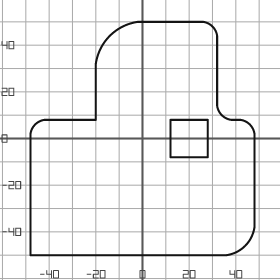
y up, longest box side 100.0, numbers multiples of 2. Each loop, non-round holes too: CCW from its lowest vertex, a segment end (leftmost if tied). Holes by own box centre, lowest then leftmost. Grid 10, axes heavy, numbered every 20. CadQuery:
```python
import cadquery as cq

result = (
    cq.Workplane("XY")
    .moveTo(-48.0, -50.0)
    .lineTo(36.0, -50.0)
    .threePointArc((44.0, -46.0), (48.0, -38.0))
    .lineTo(48.0, 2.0)
    .threePointArc((46.0, 6.0), (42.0, 8.0))
    .lineTo(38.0, 8.0)
    .threePointArc((34.0, 10.0), (32.0, 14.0))
    .lineTo(32.0, 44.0)
    .threePointArc((30.0, 48.0), (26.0, 50.0))
    .lineTo(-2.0, 50.0)
    .threePointArc((-14.0, 44.0), (-20.0, 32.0))
    .lineTo(-20.0, 8.0)
    .lineTo(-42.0, 8.0)
    .threePointArc((-46.0, 6.0), (-48.0, 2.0))
    .close()
    .moveTo(12.0, -8.0)
    .lineTo(28.0, -8.0)
    .lineTo(28.0, 8.0)
    .lineTo(12.0, 8.0)
    .close()
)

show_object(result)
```